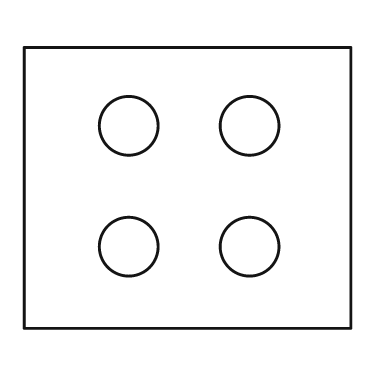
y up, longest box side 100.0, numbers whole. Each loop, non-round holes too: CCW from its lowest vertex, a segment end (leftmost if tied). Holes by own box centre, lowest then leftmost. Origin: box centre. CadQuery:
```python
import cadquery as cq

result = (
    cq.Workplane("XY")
    .moveTo(-50.0, -43.0)
    .lineTo(50.0, -43.0)
    .lineTo(50.0, 43.0)
    .lineTo(-50.0, 43.0)
    .close()
    .moveTo(-18.0, -18.0)
    .circle(9.0)
    .moveTo(19.0, -18.0)
    .circle(9.0)
    .moveTo(-18.0, 19.0)
    .circle(9.0)
    .moveTo(19.0, 19.0)
    .circle(9.0)
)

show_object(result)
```